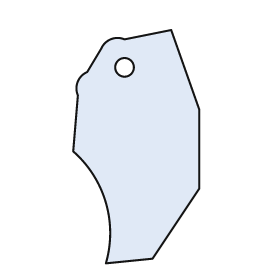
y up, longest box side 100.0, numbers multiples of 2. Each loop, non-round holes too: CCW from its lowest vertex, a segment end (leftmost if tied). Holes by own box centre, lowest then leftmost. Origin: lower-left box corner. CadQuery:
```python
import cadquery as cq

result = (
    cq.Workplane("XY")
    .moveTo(14.0, 0.0)
    .lineTo(34.0, 2.0)
    .lineTo(54.0, 32.0)
    .lineTo(54.0, 66.0)
    .lineTo(42.0, 100.0)
    .lineTo(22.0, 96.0)
    .threePointArc((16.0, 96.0), (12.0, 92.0))
    .lineTo(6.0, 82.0)
    .threePointArc((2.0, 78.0), (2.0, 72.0))
    .lineTo(0.0, 48.0)
    .threePointArc((14.0, 26.0), (14.0, 0.0))
    .close()
    .moveTo(22.0, 84.0)
    .circle(4.0)
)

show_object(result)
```